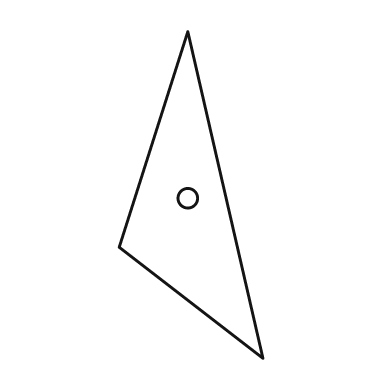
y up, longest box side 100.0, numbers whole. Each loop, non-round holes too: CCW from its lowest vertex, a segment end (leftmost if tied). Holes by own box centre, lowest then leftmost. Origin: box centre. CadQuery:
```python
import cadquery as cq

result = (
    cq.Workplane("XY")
    .moveTo(22.0, -50.0)
    .lineTo(-1.0, 50.0)
    .lineTo(-22.0, -16.0)
    .close()
    .moveTo(-1.0, -1.0)
    .circle(3.0)
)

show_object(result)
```